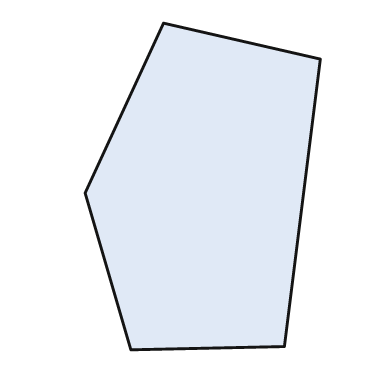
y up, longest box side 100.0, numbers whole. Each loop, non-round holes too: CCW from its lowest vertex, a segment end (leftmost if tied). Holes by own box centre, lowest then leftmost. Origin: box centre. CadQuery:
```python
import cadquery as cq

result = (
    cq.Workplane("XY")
    .moveTo(-22.0, -50.0)
    .lineTo(25.0, -49.0)
    .lineTo(36.0, 39.0)
    .lineTo(-12.0, 50.0)
    .lineTo(-36.0, -2.0)
    .close()
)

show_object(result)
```